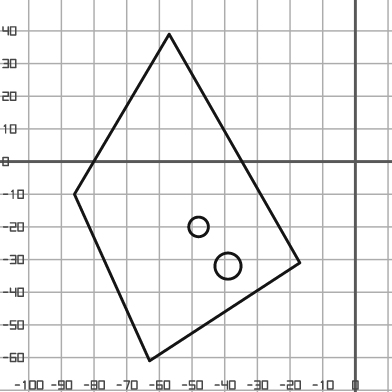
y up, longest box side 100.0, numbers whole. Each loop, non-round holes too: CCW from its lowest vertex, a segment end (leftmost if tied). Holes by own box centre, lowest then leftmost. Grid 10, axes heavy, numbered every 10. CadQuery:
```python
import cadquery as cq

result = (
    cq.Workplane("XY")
    .moveTo(-63.0, -61.0)
    .lineTo(-17.0, -31.0)
    .lineTo(-57.0, 39.0)
    .lineTo(-86.0, -10.0)
    .close()
    .moveTo(-39.0, -32.0)
    .circle(4.0)
    .moveTo(-48.0, -20.0)
    .circle(3.0)
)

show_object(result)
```